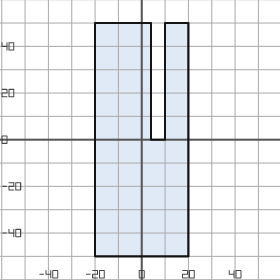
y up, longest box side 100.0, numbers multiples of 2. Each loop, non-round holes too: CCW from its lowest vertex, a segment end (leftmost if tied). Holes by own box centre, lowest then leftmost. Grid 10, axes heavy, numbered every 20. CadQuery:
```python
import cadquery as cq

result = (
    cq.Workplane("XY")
    .moveTo(-20.0, -50.0)
    .lineTo(20.0, -50.0)
    .lineTo(20.0, 50.0)
    .lineTo(10.0, 50.0)
    .lineTo(10.0, 0.0)
    .lineTo(4.0, 0.0)
    .lineTo(4.0, 50.0)
    .lineTo(-20.0, 50.0)
    .close()
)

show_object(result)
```